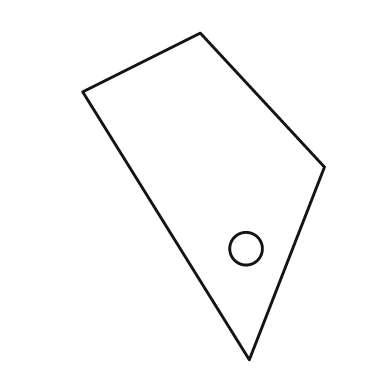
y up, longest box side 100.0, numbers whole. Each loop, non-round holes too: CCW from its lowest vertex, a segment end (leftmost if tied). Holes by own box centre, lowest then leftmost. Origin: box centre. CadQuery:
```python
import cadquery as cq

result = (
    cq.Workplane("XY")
    .moveTo(14.0, -50.0)
    .lineTo(37.0, 9.0)
    .lineTo(-1.0, 50.0)
    .lineTo(-37.0, 32.0)
    .close()
    .moveTo(13.0, -16.0)
    .circle(5.0)
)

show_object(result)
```